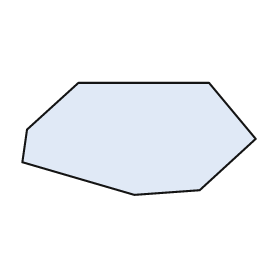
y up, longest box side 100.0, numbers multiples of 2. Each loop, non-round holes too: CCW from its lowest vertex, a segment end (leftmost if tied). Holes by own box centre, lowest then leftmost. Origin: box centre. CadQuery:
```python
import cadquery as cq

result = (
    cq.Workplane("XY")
    .moveTo(-2.0, -24.0)
    .lineTo(26.0, -22.0)
    .lineTo(50.0, 0.0)
    .lineTo(30.0, 24.0)
    .lineTo(-26.0, 24.0)
    .lineTo(-48.0, 4.0)
    .lineTo(-50.0, -10.0)
    .close()
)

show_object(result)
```